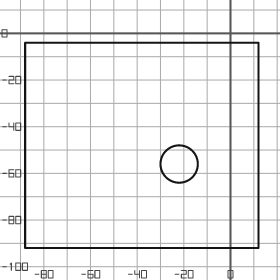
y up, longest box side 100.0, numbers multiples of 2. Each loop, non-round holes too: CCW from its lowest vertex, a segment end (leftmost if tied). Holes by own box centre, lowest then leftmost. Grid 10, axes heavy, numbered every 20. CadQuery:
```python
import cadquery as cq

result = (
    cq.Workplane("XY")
    .moveTo(-88.0, -92.0)
    .lineTo(12.0, -92.0)
    .lineTo(12.0, -4.0)
    .lineTo(-88.0, -4.0)
    .close()
    .moveTo(-22.0, -56.0)
    .circle(8.0)
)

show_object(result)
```